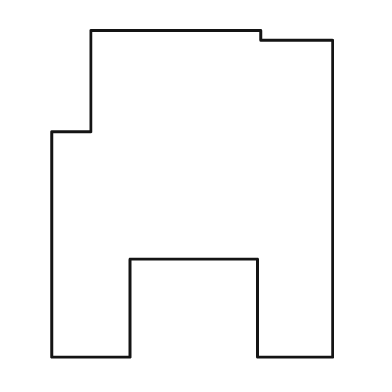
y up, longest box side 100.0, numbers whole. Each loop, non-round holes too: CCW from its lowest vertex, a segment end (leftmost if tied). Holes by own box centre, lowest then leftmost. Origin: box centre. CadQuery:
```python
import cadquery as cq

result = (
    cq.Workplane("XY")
    .moveTo(-43.0, -50.0)
    .lineTo(-19.0, -50.0)
    .lineTo(-19.0, -20.0)
    .lineTo(20.0, -20.0)
    .lineTo(20.0, -50.0)
    .lineTo(43.0, -50.0)
    .lineTo(43.0, 47.0)
    .lineTo(21.0, 47.0)
    .lineTo(21.0, 50.0)
    .lineTo(-31.0, 50.0)
    .lineTo(-31.0, 19.0)
    .lineTo(-43.0, 19.0)
    .close()
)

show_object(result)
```